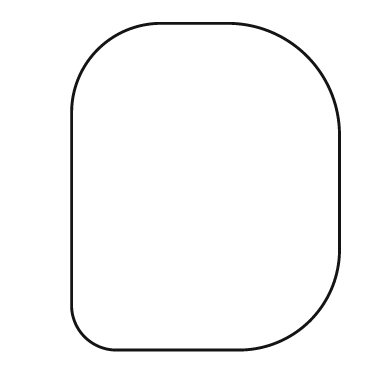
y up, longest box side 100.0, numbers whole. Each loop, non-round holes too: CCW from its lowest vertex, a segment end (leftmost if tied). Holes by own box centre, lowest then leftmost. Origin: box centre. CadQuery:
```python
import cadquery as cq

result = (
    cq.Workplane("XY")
    .moveTo(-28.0, -50.0)
    .lineTo(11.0, -50.0)
    .threePointArc((32.0, -41.0), (41.0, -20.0))
    .lineTo(41.0, 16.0)
    .threePointArc((31.0, 40.0), (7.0, 50.0))
    .lineTo(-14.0, 50.0)
    .threePointArc((-33.0, 42.0), (-41.0, 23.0))
    .lineTo(-41.0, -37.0)
    .threePointArc((-37.0, -46.0), (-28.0, -50.0))
    .close()
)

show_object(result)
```